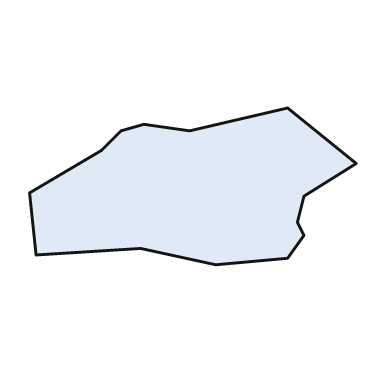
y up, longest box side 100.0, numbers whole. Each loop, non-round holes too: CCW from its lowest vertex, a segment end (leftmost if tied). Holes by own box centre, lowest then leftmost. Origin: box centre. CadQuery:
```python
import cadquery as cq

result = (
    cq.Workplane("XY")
    .moveTo(7.0, -24.0)
    .lineTo(29.0, -22.0)
    .lineTo(34.0, -15.0)
    .lineTo(32.0, -11.0)
    .lineTo(34.0, -3.0)
    .lineTo(50.0, 7.0)
    .lineTo(29.0, 24.0)
    .lineTo(-1.0, 17.0)
    .lineTo(-15.0, 19.0)
    .lineTo(-22.0, 17.0)
    .lineTo(-28.0, 11.0)
    .lineTo(-50.0, -2.0)
    .lineTo(-48.0, -21.0)
    .lineTo(-16.0, -19.0)
    .close()
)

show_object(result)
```